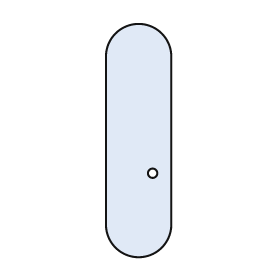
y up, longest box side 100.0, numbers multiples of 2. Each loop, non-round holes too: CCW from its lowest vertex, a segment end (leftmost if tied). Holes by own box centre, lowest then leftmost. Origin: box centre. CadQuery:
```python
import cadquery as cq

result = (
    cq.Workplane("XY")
    .moveTo(-14.0, -36.0)
    .threePointArc((0.0, -50.0), (14.0, -36.0))
    .lineTo(14.0, 36.0)
    .threePointArc((0.0, 50.0), (-14.0, 36.0))
    .close()
    .moveTo(6.0, -14.0)
    .circle(2.0)
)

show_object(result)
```